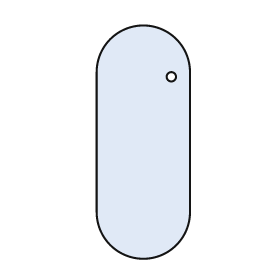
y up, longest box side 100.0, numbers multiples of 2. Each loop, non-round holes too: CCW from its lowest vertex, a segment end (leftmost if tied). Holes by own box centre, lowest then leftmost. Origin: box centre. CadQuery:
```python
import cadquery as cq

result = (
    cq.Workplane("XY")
    .moveTo(-20.0, -30.0)
    .threePointArc((0.0, -50.0), (20.0, -30.0))
    .lineTo(20.0, 30.0)
    .threePointArc((0.0, 50.0), (-20.0, 30.0))
    .close()
    .moveTo(12.0, 28.0)
    .circle(2.0)
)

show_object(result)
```